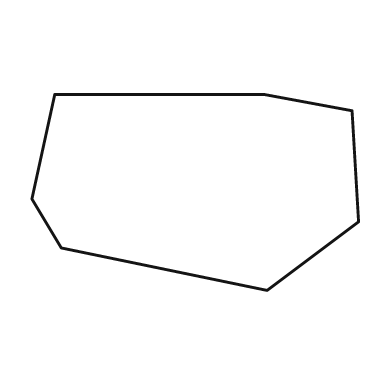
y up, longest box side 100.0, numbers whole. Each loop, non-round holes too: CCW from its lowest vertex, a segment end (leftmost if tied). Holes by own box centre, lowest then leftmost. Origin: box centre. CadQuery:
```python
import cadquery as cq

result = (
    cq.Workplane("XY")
    .moveTo(22.0, -30.0)
    .lineTo(50.0, -9.0)
    .lineTo(48.0, 25.0)
    .lineTo(21.0, 30.0)
    .lineTo(-43.0, 30.0)
    .lineTo(-50.0, -2.0)
    .lineTo(-41.0, -17.0)
    .close()
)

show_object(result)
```